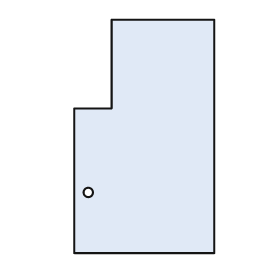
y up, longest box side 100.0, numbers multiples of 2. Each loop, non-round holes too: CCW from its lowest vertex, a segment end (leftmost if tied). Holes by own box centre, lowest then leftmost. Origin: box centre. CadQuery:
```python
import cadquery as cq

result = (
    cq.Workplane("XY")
    .moveTo(-30.0, -50.0)
    .lineTo(30.0, -50.0)
    .lineTo(30.0, 50.0)
    .lineTo(-14.0, 50.0)
    .lineTo(-14.0, 12.0)
    .lineTo(-30.0, 12.0)
    .close()
    .moveTo(-24.0, -24.0)
    .circle(2.0)
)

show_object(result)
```